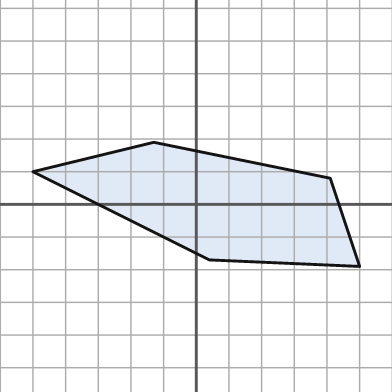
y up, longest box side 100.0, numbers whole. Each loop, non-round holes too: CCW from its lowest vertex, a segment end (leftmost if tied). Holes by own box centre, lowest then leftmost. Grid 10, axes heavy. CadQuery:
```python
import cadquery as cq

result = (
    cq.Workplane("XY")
    .moveTo(50.0, -19.0)
    .lineTo(41.0, 8.0)
    .lineTo(-13.0, 19.0)
    .lineTo(-50.0, 10.0)
    .lineTo(4.0, -17.0)
    .close()
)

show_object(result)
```